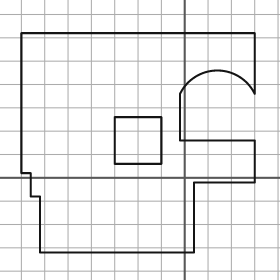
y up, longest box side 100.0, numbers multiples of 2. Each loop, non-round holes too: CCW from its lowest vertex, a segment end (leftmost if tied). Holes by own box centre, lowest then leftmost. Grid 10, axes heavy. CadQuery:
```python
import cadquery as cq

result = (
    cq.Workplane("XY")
    .moveTo(-62.0, -32.0)
    .lineTo(4.0, -32.0)
    .lineTo(4.0, -2.0)
    .lineTo(30.0, -2.0)
    .lineTo(30.0, 16.0)
    .lineTo(-2.0, 16.0)
    .lineTo(-2.0, 36.0)
    .threePointArc((14.0, 46.0), (30.0, 36.0))
    .lineTo(30.0, 62.0)
    .lineTo(-70.0, 62.0)
    .lineTo(-70.0, 2.0)
    .lineTo(-66.0, 2.0)
    .lineTo(-66.0, -8.0)
    .lineTo(-62.0, -8.0)
    .close()
    .moveTo(-30.0, 6.0)
    .lineTo(-10.0, 6.0)
    .lineTo(-10.0, 26.0)
    .lineTo(-30.0, 26.0)
    .close()
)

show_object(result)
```